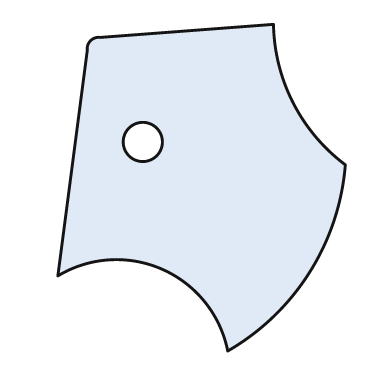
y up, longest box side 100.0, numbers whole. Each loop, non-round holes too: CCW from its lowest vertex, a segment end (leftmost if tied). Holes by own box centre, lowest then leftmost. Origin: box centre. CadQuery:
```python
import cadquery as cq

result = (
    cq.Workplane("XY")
    .moveTo(8.0, -50.0)
    .threePointArc((33.0, -26.0), (44.0, 7.0))
    .threePointArc((28.0, 26.0), (22.0, 50.0))
    .lineTo(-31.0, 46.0)
    .threePointArc((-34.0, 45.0), (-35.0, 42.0))
    .lineTo(-44.0, -27.0)
    .threePointArc((-12.0, -25.0), (8.0, -50.0))
    .close()
    .moveTo(-18.0, 14.0)
    .circle(6.0)
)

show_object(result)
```